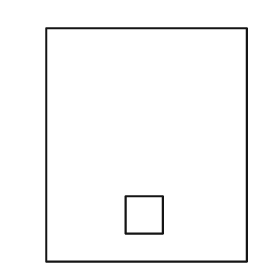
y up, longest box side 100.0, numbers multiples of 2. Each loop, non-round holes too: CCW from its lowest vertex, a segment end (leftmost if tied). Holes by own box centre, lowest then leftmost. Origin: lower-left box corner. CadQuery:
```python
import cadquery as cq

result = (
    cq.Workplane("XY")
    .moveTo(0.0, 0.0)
    .lineTo(86.0, 0.0)
    .lineTo(86.0, 100.0)
    .lineTo(0.0, 100.0)
    .close()
    .moveTo(34.0, 12.0)
    .lineTo(50.0, 12.0)
    .lineTo(50.0, 28.0)
    .lineTo(34.0, 28.0)
    .close()
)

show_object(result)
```